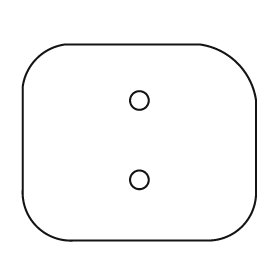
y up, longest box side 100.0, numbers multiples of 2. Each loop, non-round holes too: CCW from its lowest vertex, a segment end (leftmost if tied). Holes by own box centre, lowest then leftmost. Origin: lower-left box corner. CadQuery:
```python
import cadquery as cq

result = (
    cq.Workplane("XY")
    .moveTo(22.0, 0.0)
    .lineTo(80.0, 0.0)
    .threePointArc((94.0, 6.0), (100.0, 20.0))
    .lineTo(100.0, 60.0)
    .threePointArc((92.0, 76.0), (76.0, 84.0))
    .lineTo(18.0, 84.0)
    .threePointArc((6.0, 78.0), (0.0, 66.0))
    .lineTo(0.0, 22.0)
    .threePointArc((6.0, 6.0), (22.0, 0.0))
    .close()
    .moveTo(50.0, 26.0)
    .circle(4.0)
    .moveTo(50.0, 60.0)
    .circle(4.0)
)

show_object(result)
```